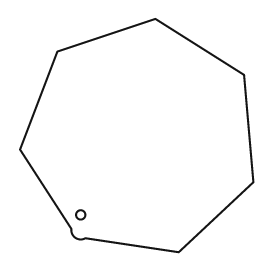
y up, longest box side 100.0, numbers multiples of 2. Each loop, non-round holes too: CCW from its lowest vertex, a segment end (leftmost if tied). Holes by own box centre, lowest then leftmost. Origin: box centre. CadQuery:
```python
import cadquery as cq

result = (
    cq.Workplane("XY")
    .moveTo(18.0, -50.0)
    .lineTo(50.0, -20.0)
    .lineTo(46.0, 26.0)
    .lineTo(8.0, 50.0)
    .lineTo(-34.0, 36.0)
    .lineTo(-50.0, -6.0)
    .lineTo(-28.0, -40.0)
    .threePointArc((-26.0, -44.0), (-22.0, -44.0))
    .close()
    .moveTo(-24.0, -34.0)
    .circle(2.0)
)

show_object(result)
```